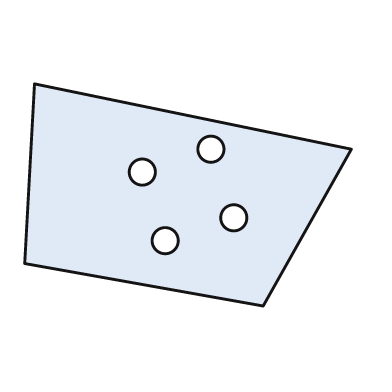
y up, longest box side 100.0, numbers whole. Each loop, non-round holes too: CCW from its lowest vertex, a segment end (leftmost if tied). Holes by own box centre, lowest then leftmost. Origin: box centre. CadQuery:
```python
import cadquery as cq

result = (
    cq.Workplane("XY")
    .moveTo(23.0, -34.0)
    .lineTo(50.0, 14.0)
    .lineTo(-47.0, 34.0)
    .lineTo(-50.0, -21.0)
    .close()
    .moveTo(-7.0, -14.0)
    .circle(4.0)
    .moveTo(14.0, -7.0)
    .circle(4.0)
    .moveTo(-14.0, 7.0)
    .circle(4.0)
    .moveTo(7.0, 14.0)
    .circle(4.0)
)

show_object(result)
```